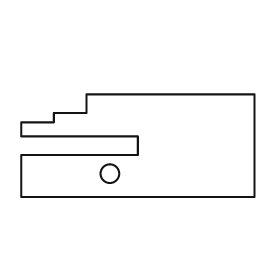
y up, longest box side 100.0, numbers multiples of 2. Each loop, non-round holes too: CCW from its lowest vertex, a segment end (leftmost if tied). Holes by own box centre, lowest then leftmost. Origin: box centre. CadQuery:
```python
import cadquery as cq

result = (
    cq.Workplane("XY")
    .moveTo(-50.0, -22.0)
    .lineTo(50.0, -22.0)
    .lineTo(50.0, 22.0)
    .lineTo(-22.0, 22.0)
    .lineTo(-22.0, 14.0)
    .lineTo(-36.0, 14.0)
    .lineTo(-36.0, 10.0)
    .lineTo(-50.0, 10.0)
    .lineTo(-50.0, 4.0)
    .lineTo(0.0, 4.0)
    .lineTo(0.0, -4.0)
    .lineTo(-50.0, -4.0)
    .close()
    .moveTo(-12.0, -12.0)
    .circle(4.0)
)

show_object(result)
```